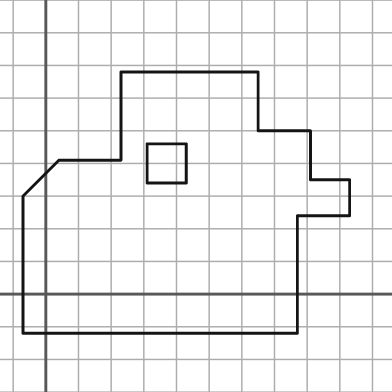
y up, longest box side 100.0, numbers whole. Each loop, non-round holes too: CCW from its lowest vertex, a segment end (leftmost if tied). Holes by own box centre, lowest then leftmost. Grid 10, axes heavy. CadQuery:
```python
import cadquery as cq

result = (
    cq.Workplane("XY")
    .moveTo(-7.0, -12.0)
    .lineTo(77.0, -12.0)
    .lineTo(77.0, 24.0)
    .lineTo(93.0, 24.0)
    .lineTo(93.0, 35.0)
    .lineTo(81.0, 35.0)
    .lineTo(81.0, 50.0)
    .lineTo(65.0, 50.0)
    .lineTo(65.0, 68.0)
    .lineTo(23.0, 68.0)
    .lineTo(23.0, 41.0)
    .lineTo(4.0, 41.0)
    .lineTo(-7.0, 30.0)
    .close()
    .moveTo(31.0, 34.0)
    .lineTo(43.0, 34.0)
    .lineTo(43.0, 46.0)
    .lineTo(31.0, 46.0)
    .close()
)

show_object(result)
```